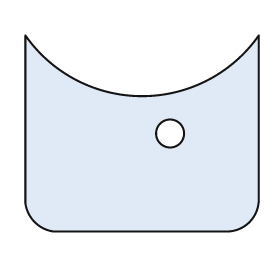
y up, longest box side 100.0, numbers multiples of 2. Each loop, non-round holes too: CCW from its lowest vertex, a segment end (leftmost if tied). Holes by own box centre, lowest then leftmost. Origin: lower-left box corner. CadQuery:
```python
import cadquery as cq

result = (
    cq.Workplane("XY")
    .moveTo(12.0, 0.0)
    .lineTo(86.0, 0.0)
    .threePointArc((96.0, 4.0), (100.0, 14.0))
    .lineTo(100.0, 84.0)
    .threePointArc((50.0, 58.0), (0.0, 84.0))
    .lineTo(0.0, 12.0)
    .threePointArc((4.0, 4.0), (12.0, 0.0))
    .close()
    .moveTo(62.0, 42.0)
    .circle(6.0)
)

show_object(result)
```